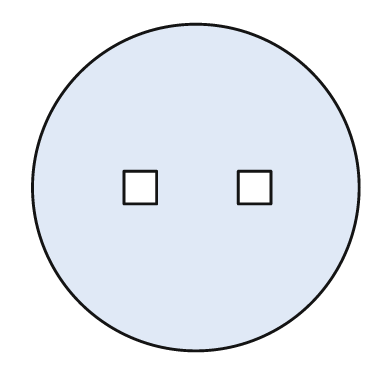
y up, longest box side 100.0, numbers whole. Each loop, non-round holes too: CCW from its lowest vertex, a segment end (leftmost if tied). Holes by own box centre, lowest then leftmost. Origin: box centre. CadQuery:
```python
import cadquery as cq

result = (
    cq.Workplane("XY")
    .moveTo(0.0, 0.0)
    .circle(50.0)
    .moveTo(-22.0, -5.0)
    .lineTo(-12.0, -5.0)
    .lineTo(-12.0, 5.0)
    .lineTo(-22.0, 5.0)
    .close()
    .moveTo(13.0, -5.0)
    .lineTo(23.0, -5.0)
    .lineTo(23.0, 5.0)
    .lineTo(13.0, 5.0)
    .close()
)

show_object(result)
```